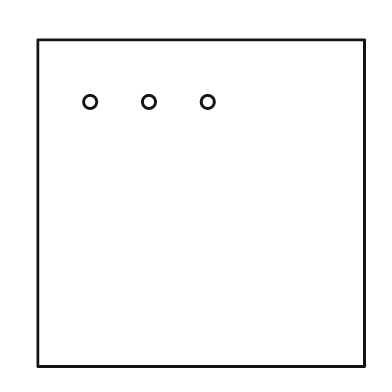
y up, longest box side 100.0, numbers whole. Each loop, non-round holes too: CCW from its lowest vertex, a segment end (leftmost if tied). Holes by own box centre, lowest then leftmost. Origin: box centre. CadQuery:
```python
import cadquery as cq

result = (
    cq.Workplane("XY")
    .moveTo(-50.0, -50.0)
    .lineTo(50.0, -50.0)
    .lineTo(50.0, 50.0)
    .lineTo(-50.0, 50.0)
    .close()
    .moveTo(-34.0, 31.0)
    .circle(2.0)
    .moveTo(-16.0, 31.0)
    .circle(2.0)
    .moveTo(2.0, 31.0)
    .circle(2.0)
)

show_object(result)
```